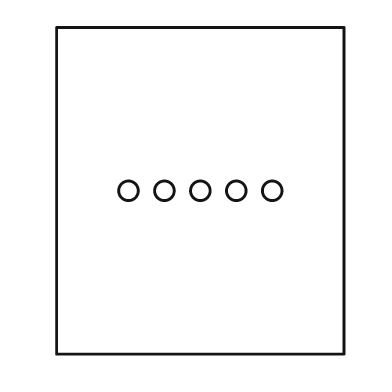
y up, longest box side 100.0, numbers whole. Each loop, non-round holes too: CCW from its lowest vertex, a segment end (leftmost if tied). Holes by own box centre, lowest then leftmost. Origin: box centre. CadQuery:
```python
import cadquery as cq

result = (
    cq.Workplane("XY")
    .moveTo(-44.0, -50.0)
    .lineTo(44.0, -50.0)
    .lineTo(44.0, 50.0)
    .lineTo(-44.0, 50.0)
    .close()
    .moveTo(-22.0, 0.0)
    .circle(3.0)
    .moveTo(-11.0, 0.0)
    .circle(3.0)
    .moveTo(0.0, 0.0)
    .circle(3.0)
    .moveTo(11.0, 0.0)
    .circle(3.0)
    .moveTo(22.0, 0.0)
    .circle(3.0)
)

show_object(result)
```